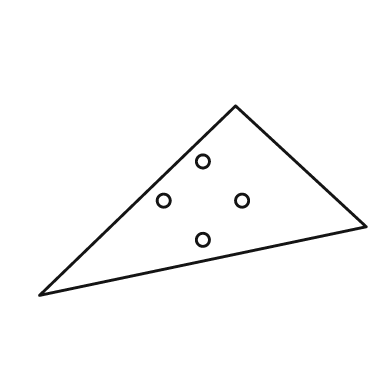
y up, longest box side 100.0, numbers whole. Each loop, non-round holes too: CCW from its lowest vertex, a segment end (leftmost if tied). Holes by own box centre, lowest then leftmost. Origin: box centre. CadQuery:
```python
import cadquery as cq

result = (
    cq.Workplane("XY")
    .moveTo(-50.0, -29.0)
    .lineTo(50.0, -8.0)
    .lineTo(10.0, 29.0)
    .close()
    .moveTo(0.0, -12.0)
    .circle(2.0)
    .moveTo(-12.0, 0.0)
    .circle(2.0)
    .moveTo(12.0, 0.0)
    .circle(2.0)
    .moveTo(0.0, 12.0)
    .circle(2.0)
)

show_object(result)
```